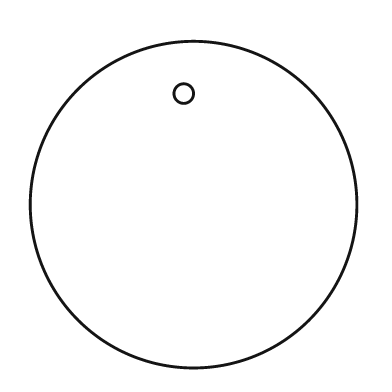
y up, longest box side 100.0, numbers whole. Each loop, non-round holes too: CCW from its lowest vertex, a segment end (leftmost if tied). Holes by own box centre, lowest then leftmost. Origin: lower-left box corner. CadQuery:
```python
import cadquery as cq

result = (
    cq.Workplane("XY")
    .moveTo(50.0, 50.0)
    .circle(50.0)
    .moveTo(47.0, 84.0)
    .circle(3.0)
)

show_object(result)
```